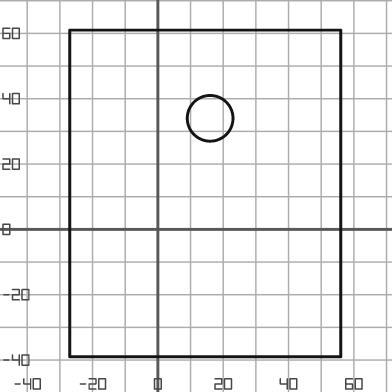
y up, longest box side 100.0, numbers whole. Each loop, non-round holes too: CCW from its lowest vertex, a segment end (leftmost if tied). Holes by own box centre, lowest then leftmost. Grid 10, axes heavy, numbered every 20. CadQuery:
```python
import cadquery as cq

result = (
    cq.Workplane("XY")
    .moveTo(-27.0, -39.0)
    .lineTo(56.0, -39.0)
    .lineTo(56.0, 61.0)
    .lineTo(-27.0, 61.0)
    .close()
    .moveTo(16.0, 34.0)
    .circle(7.0)
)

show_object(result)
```